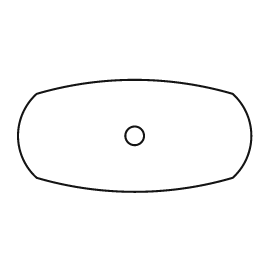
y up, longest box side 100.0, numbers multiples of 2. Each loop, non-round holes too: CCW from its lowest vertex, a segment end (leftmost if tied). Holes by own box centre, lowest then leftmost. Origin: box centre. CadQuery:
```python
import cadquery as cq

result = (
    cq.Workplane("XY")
    .moveTo(-42.0, -18.0)
    .threePointArc((0.0, -24.0), (42.0, -18.0))
    .threePointArc((50.0, 0.0), (42.0, 18.0))
    .threePointArc((0.0, 24.0), (-42.0, 18.0))
    .threePointArc((-50.0, 0.0), (-42.0, -18.0))
    .close()
    .moveTo(0.0, 0.0)
    .circle(4.0)
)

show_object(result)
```